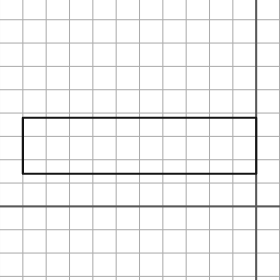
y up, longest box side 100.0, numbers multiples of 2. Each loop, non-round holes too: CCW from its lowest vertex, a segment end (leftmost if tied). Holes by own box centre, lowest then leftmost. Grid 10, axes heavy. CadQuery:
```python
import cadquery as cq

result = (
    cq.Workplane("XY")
    .moveTo(-100.0, 14.0)
    .lineTo(0.0, 14.0)
    .lineTo(0.0, 38.0)
    .lineTo(-100.0, 38.0)
    .close()
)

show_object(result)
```